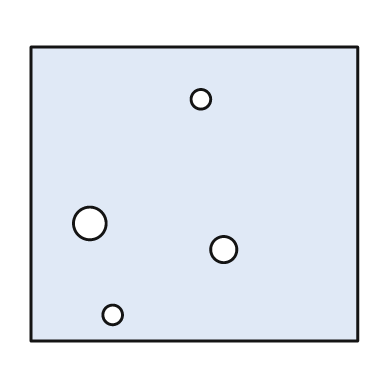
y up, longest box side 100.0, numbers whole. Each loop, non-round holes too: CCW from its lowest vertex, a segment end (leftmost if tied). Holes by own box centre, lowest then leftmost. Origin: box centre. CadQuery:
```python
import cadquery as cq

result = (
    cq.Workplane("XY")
    .moveTo(-50.0, -45.0)
    .lineTo(50.0, -45.0)
    .lineTo(50.0, 45.0)
    .lineTo(-50.0, 45.0)
    .close()
    .moveTo(-25.0, -37.0)
    .circle(3.0)
    .moveTo(9.0, -17.0)
    .circle(4.0)
    .moveTo(-32.0, -9.0)
    .circle(5.0)
    .moveTo(2.0, 29.0)
    .circle(3.0)
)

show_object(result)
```